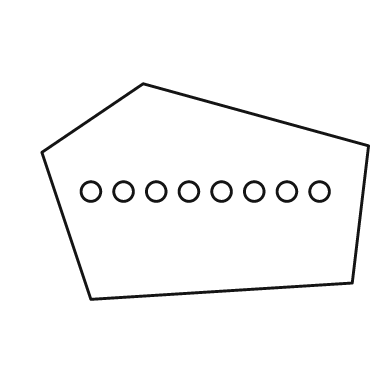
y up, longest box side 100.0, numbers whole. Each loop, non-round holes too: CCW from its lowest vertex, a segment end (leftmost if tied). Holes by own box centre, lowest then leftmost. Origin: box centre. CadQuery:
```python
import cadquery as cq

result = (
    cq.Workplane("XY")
    .moveTo(-35.0, -33.0)
    .lineTo(45.0, -28.0)
    .lineTo(50.0, 14.0)
    .lineTo(-19.0, 33.0)
    .lineTo(-50.0, 12.0)
    .close()
    .moveTo(-35.0, 0.0)
    .circle(3.0)
    .moveTo(-25.0, 0.0)
    .circle(3.0)
    .moveTo(-15.0, 0.0)
    .circle(3.0)
    .moveTo(-5.0, 0.0)
    .circle(3.0)
    .moveTo(5.0, 0.0)
    .circle(3.0)
    .moveTo(15.0, 0.0)
    .circle(3.0)
    .moveTo(25.0, 0.0)
    .circle(3.0)
    .moveTo(35.0, 0.0)
    .circle(3.0)
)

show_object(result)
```